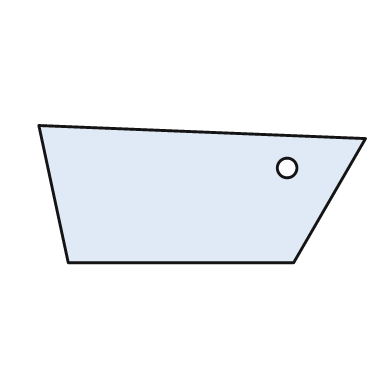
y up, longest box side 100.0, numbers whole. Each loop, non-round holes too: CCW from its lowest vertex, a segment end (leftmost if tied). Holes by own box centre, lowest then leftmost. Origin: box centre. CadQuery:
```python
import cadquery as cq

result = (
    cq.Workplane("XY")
    .moveTo(-41.0, -21.0)
    .lineTo(28.0, -21.0)
    .lineTo(50.0, 17.0)
    .lineTo(-50.0, 21.0)
    .close()
    .moveTo(26.0, 8.0)
    .circle(3.0)
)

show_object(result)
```